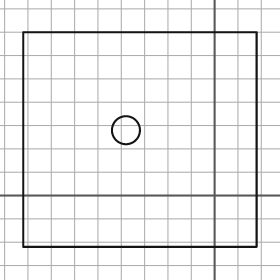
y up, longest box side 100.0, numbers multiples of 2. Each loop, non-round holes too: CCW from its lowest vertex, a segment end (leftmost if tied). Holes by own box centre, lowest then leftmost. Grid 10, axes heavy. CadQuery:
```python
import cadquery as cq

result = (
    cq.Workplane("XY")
    .moveTo(-82.0, -22.0)
    .lineTo(18.0, -22.0)
    .lineTo(18.0, 70.0)
    .lineTo(-82.0, 70.0)
    .close()
    .moveTo(-38.0, 28.0)
    .circle(6.0)
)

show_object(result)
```